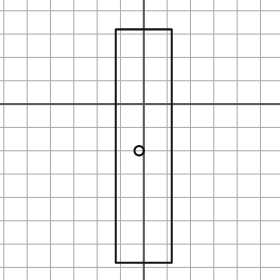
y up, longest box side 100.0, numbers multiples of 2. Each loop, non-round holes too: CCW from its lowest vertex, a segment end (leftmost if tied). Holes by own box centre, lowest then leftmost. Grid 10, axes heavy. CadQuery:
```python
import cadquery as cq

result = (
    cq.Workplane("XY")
    .moveTo(-12.0, -68.0)
    .lineTo(12.0, -68.0)
    .lineTo(12.0, 32.0)
    .lineTo(-12.0, 32.0)
    .close()
    .moveTo(-2.0, -20.0)
    .circle(2.0)
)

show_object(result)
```